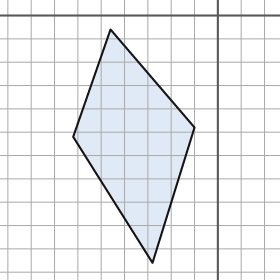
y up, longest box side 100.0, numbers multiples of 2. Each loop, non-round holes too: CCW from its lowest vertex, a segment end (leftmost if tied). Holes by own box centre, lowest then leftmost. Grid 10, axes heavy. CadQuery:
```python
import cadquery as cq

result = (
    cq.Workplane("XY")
    .moveTo(-28.0, -106.0)
    .lineTo(-10.0, -48.0)
    .lineTo(-46.0, -6.0)
    .lineTo(-62.0, -52.0)
    .close()
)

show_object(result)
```